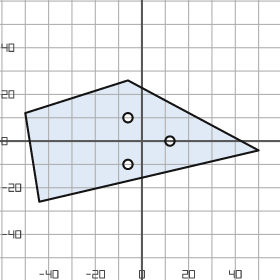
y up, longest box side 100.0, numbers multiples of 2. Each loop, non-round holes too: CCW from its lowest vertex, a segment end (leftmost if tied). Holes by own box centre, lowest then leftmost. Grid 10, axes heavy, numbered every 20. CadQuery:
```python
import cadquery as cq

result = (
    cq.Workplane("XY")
    .moveTo(-44.0, -26.0)
    .lineTo(50.0, -4.0)
    .lineTo(-6.0, 26.0)
    .lineTo(-50.0, 12.0)
    .close()
    .moveTo(-6.0, -10.0)
    .circle(2.0)
    .moveTo(12.0, 0.0)
    .circle(2.0)
    .moveTo(-6.0, 10.0)
    .circle(2.0)
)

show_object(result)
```